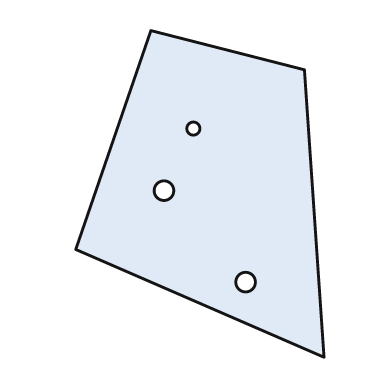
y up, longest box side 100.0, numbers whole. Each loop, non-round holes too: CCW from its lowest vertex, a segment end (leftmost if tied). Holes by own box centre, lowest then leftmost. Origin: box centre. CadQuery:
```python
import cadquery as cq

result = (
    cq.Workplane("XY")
    .moveTo(38.0, -50.0)
    .lineTo(32.0, 38.0)
    .lineTo(-15.0, 50.0)
    .lineTo(-38.0, -17.0)
    .close()
    .moveTo(14.0, -27.0)
    .circle(3.0)
    .moveTo(-11.0, 1.0)
    .circle(3.0)
    .moveTo(-2.0, 20.0)
    .circle(2.0)
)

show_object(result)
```